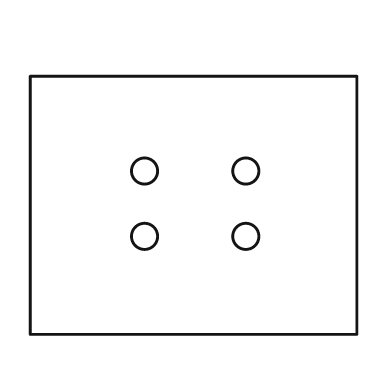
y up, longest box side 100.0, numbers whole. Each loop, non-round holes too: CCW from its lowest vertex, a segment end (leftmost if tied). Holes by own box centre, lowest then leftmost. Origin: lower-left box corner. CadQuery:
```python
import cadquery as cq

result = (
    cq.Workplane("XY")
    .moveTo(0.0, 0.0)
    .lineTo(100.0, 0.0)
    .lineTo(100.0, 79.0)
    .lineTo(0.0, 79.0)
    .close()
    .moveTo(35.0, 30.0)
    .circle(4.0)
    .moveTo(66.0, 30.0)
    .circle(4.0)
    .moveTo(35.0, 50.0)
    .circle(4.0)
    .moveTo(66.0, 50.0)
    .circle(4.0)
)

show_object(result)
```